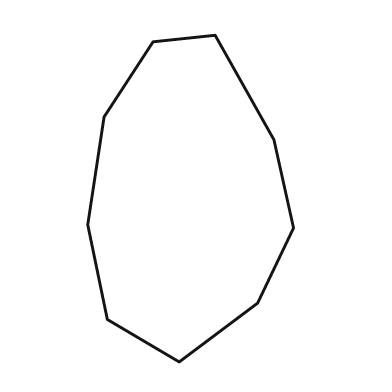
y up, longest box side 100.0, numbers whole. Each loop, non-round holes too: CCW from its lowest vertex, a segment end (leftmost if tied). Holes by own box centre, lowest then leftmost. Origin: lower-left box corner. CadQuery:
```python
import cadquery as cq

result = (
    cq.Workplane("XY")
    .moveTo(28.0, 0.0)
    .lineTo(52.0, 18.0)
    .lineTo(63.0, 41.0)
    .lineTo(57.0, 68.0)
    .lineTo(39.0, 100.0)
    .lineTo(20.0, 98.0)
    .lineTo(5.0, 75.0)
    .lineTo(0.0, 42.0)
    .lineTo(6.0, 13.0)
    .close()
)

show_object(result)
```